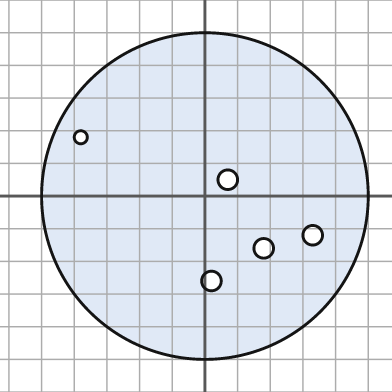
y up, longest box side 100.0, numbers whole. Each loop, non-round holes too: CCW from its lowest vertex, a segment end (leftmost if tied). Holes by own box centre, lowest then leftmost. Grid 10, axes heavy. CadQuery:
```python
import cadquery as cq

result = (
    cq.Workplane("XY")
    .moveTo(0.0, 0.0)
    .circle(50.0)
    .moveTo(2.0, -26.0)
    .circle(3.0)
    .moveTo(18.0, -16.0)
    .circle(3.0)
    .moveTo(33.0, -12.0)
    .circle(3.0)
    .moveTo(7.0, 5.0)
    .circle(3.0)
    .moveTo(-38.0, 18.0)
    .circle(2.0)
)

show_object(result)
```